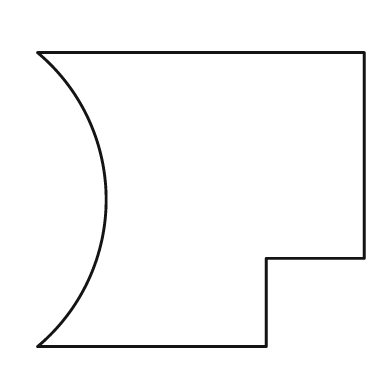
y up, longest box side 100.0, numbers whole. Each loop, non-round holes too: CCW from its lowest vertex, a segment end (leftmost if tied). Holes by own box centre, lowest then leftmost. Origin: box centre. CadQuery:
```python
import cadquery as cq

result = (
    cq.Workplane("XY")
    .moveTo(-50.0, -45.0)
    .lineTo(20.0, -45.0)
    .lineTo(20.0, -18.0)
    .lineTo(50.0, -18.0)
    .lineTo(50.0, 45.0)
    .lineTo(-50.0, 45.0)
    .threePointArc((-29.0, 0.0), (-50.0, -45.0))
    .close()
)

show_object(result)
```